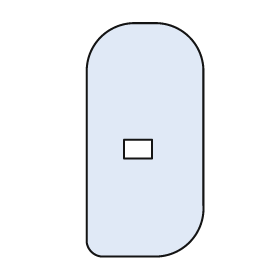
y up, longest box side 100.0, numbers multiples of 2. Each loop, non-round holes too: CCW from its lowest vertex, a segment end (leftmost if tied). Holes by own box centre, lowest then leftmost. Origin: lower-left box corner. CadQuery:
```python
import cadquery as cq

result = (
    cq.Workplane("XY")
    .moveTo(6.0, 0.0)
    .lineTo(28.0, 0.0)
    .threePointArc((44.0, 6.0), (50.0, 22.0))
    .lineTo(50.0, 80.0)
    .threePointArc((44.0, 94.0), (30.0, 100.0))
    .lineTo(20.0, 100.0)
    .threePointArc((6.0, 94.0), (0.0, 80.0))
    .lineTo(0.0, 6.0)
    .threePointArc((2.0, 2.0), (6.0, 0.0))
    .close()
    .moveTo(16.0, 42.0)
    .lineTo(28.0, 42.0)
    .lineTo(28.0, 50.0)
    .lineTo(16.0, 50.0)
    .close()
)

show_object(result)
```